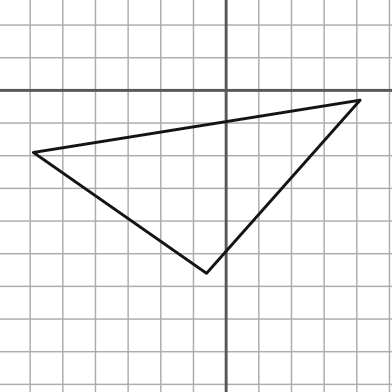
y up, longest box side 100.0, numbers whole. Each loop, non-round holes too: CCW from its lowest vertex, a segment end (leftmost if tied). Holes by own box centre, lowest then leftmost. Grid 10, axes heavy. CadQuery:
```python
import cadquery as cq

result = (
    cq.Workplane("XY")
    .moveTo(-6.0, -56.0)
    .lineTo(41.0, -3.0)
    .lineTo(-59.0, -19.0)
    .close()
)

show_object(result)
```